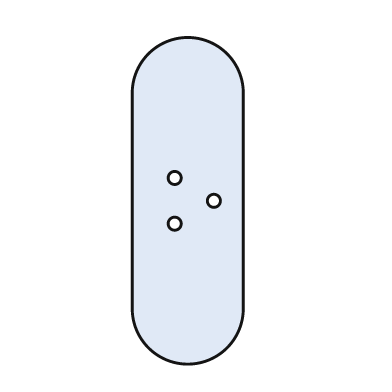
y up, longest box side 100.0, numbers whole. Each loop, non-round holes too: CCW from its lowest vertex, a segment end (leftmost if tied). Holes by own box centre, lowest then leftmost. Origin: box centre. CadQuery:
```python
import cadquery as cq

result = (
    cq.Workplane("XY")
    .moveTo(-17.0, -33.0)
    .threePointArc((0.0, -50.0), (17.0, -33.0))
    .lineTo(17.0, 33.0)
    .threePointArc((0.0, 50.0), (-17.0, 33.0))
    .close()
    .moveTo(-4.0, -7.0)
    .circle(2.0)
    .moveTo(8.0, 0.0)
    .circle(2.0)
    .moveTo(-4.0, 7.0)
    .circle(2.0)
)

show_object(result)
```